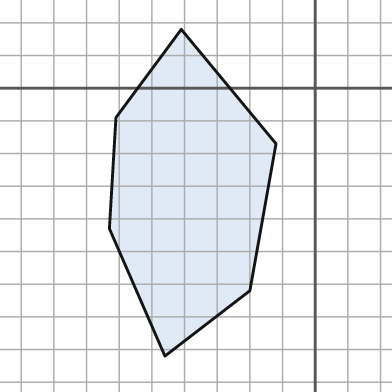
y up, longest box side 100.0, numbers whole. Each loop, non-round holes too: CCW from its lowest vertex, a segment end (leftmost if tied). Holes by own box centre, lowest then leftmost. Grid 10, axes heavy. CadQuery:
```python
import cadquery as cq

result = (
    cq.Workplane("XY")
    .moveTo(-46.0, -82.0)
    .lineTo(-20.0, -62.0)
    .lineTo(-12.0, -17.0)
    .lineTo(-41.0, 18.0)
    .lineTo(-61.0, -9.0)
    .lineTo(-63.0, -43.0)
    .close()
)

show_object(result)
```